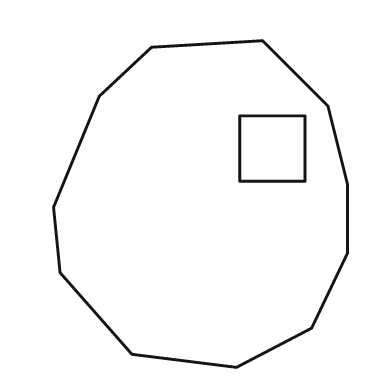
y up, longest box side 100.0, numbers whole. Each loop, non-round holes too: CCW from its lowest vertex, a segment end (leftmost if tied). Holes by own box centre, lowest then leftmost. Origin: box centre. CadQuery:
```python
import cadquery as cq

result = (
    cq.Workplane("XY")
    .moveTo(11.0, -50.0)
    .lineTo(34.0, -38.0)
    .lineTo(45.0, -15.0)
    .lineTo(45.0, 6.0)
    .lineTo(39.0, 30.0)
    .lineTo(19.0, 50.0)
    .lineTo(-15.0, 48.0)
    .lineTo(-31.0, 33.0)
    .lineTo(-45.0, -1.0)
    .lineTo(-43.0, -21.0)
    .lineTo(-21.0, -46.0)
    .close()
    .moveTo(12.0, 7.0)
    .lineTo(32.0, 7.0)
    .lineTo(32.0, 27.0)
    .lineTo(12.0, 27.0)
    .close()
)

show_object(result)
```